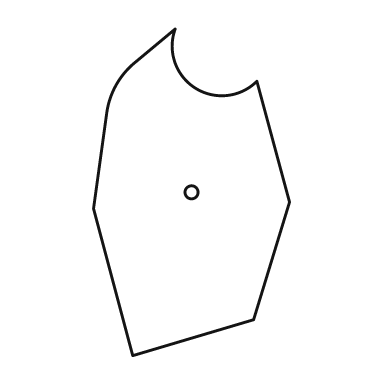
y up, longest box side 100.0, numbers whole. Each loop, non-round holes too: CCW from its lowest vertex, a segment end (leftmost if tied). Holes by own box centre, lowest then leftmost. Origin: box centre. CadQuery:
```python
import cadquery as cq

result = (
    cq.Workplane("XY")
    .moveTo(-18.0, -50.0)
    .lineTo(19.0, -39.0)
    .lineTo(30.0, -3.0)
    .lineTo(20.0, 34.0)
    .threePointArc((1.0, 32.0), (-5.0, 50.0))
    .lineTo(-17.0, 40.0)
    .threePointArc((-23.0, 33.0), (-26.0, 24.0))
    .lineTo(-30.0, -5.0)
    .close()
    .moveTo(0.0, 0.0)
    .circle(2.0)
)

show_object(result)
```